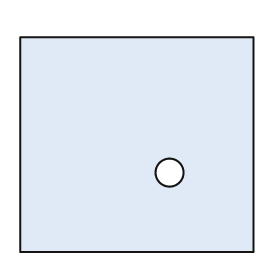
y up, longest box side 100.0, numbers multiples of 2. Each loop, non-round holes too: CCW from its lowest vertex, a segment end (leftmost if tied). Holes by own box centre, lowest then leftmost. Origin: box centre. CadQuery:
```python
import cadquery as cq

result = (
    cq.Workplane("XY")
    .moveTo(-50.0, -46.0)
    .lineTo(50.0, -46.0)
    .lineTo(50.0, 46.0)
    .lineTo(-50.0, 46.0)
    .close()
    .moveTo(14.0, -12.0)
    .circle(6.0)
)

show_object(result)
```